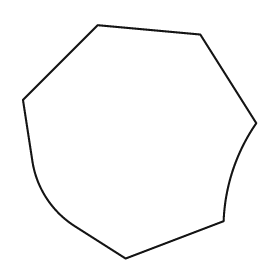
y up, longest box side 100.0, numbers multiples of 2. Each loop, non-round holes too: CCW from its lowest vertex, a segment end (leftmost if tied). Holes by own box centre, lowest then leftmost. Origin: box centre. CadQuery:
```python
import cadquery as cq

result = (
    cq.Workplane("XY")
    .moveTo(-6.0, -50.0)
    .lineTo(36.0, -34.0)
    .threePointArc((40.0, -12.0), (50.0, 8.0))
    .lineTo(26.0, 46.0)
    .lineTo(-18.0, 50.0)
    .lineTo(-50.0, 18.0)
    .lineTo(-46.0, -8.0)
    .threePointArc((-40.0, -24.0), (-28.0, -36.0))
    .close()
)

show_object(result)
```